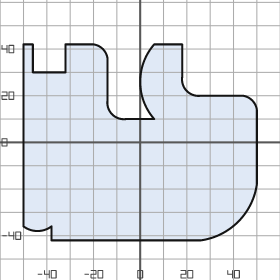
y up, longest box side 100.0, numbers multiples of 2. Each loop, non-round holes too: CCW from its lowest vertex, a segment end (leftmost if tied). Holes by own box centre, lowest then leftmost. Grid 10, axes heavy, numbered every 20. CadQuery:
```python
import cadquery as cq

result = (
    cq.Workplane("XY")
    .moveTo(-38.0, -42.0)
    .lineTo(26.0, -42.0)
    .threePointArc((42.0, -34.0), (50.0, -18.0))
    .lineTo(50.0, 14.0)
    .threePointArc((48.0, 18.0), (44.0, 20.0))
    .lineTo(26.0, 20.0)
    .threePointArc((20.0, 22.0), (18.0, 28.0))
    .lineTo(18.0, 42.0)
    .lineTo(6.0, 42.0)
    .threePointArc((0.0, 26.0), (6.0, 10.0))
    .lineTo(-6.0, 10.0)
    .threePointArc((-12.0, 12.0), (-14.0, 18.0))
    .lineTo(-14.0, 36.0)
    .threePointArc((-16.0, 40.0), (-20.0, 42.0))
    .lineTo(-32.0, 42.0)
    .lineTo(-32.0, 30.0)
    .lineTo(-46.0, 30.0)
    .lineTo(-46.0, 42.0)
    .lineTo(-50.0, 42.0)
    .lineTo(-50.0, -36.0)
    .threePointArc((-44.0, -38.0), (-38.0, -36.0))
    .close()
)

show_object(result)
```